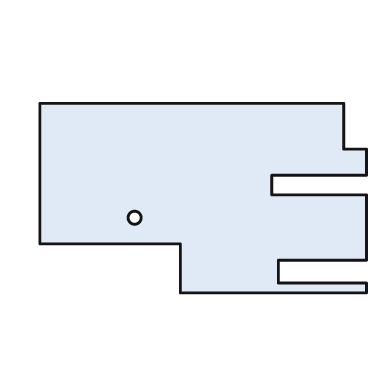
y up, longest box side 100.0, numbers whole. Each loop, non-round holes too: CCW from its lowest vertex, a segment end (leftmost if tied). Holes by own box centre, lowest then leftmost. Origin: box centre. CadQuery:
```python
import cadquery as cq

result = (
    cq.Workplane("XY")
    .moveTo(-7.0, -29.0)
    .lineTo(50.0, -29.0)
    .lineTo(50.0, -26.0)
    .lineTo(23.0, -26.0)
    .lineTo(23.0, -19.0)
    .lineTo(50.0, -19.0)
    .lineTo(50.0, 1.0)
    .lineTo(21.0, 1.0)
    .lineTo(21.0, 7.0)
    .lineTo(50.0, 7.0)
    .lineTo(50.0, 15.0)
    .lineTo(43.0, 15.0)
    .lineTo(43.0, 29.0)
    .lineTo(-50.0, 29.0)
    .lineTo(-50.0, -14.0)
    .lineTo(-7.0, -14.0)
    .close()
    .moveTo(-21.0, -6.0)
    .circle(2.0)
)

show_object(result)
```